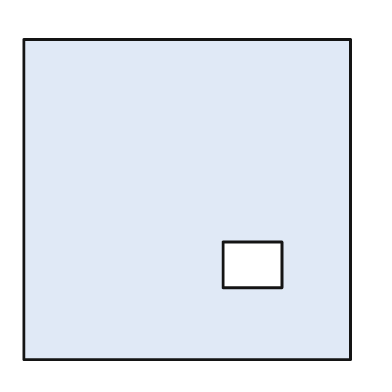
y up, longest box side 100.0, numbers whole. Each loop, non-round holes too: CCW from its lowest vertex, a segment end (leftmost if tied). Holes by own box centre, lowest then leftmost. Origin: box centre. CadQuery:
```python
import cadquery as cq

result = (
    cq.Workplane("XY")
    .moveTo(-50.0, -49.0)
    .lineTo(50.0, -49.0)
    .lineTo(50.0, 49.0)
    .lineTo(-50.0, 49.0)
    .close()
    .moveTo(11.0, -27.0)
    .lineTo(29.0, -27.0)
    .lineTo(29.0, -13.0)
    .lineTo(11.0, -13.0)
    .close()
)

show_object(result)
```